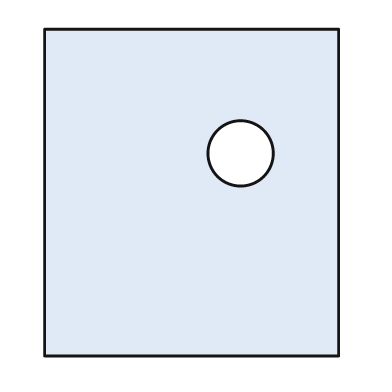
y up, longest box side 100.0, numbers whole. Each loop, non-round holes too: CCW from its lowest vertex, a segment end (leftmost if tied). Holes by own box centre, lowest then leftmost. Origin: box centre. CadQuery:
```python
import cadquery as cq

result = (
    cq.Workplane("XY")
    .moveTo(-45.0, -50.0)
    .lineTo(45.0, -50.0)
    .lineTo(45.0, 50.0)
    .lineTo(-45.0, 50.0)
    .close()
    .moveTo(15.0, 12.0)
    .circle(10.0)
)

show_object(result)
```